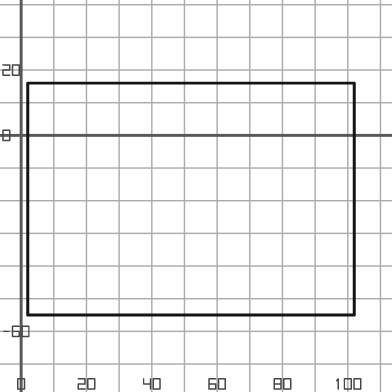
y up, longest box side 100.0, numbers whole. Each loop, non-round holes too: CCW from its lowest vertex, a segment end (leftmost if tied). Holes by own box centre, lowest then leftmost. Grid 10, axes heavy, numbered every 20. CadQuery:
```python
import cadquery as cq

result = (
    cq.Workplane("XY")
    .moveTo(2.0, -55.0)
    .lineTo(102.0, -55.0)
    .lineTo(102.0, 16.0)
    .lineTo(2.0, 16.0)
    .close()
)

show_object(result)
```